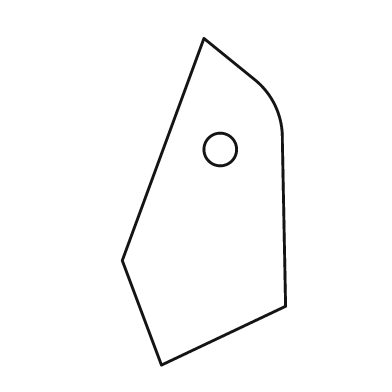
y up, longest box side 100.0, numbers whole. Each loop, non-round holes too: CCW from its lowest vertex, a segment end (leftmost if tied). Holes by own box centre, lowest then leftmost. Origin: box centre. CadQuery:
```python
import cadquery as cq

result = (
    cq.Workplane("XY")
    .moveTo(-13.0, -50.0)
    .lineTo(25.0, -32.0)
    .lineTo(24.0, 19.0)
    .threePointArc((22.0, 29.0), (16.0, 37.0))
    .lineTo(0.0, 50.0)
    .lineTo(-25.0, -18.0)
    .close()
    .moveTo(5.0, 16.0)
    .circle(5.0)
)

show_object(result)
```